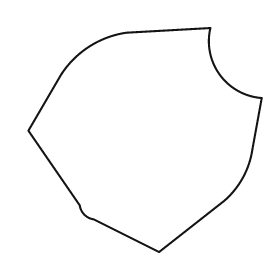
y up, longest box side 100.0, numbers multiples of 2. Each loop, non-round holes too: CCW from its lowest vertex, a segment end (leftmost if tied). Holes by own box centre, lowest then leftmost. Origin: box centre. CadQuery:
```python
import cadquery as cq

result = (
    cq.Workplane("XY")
    .moveTo(6.0, -48.0)
    .lineTo(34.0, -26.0)
    .threePointArc((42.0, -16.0), (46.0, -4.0))
    .lineTo(50.0, 18.0)
    .threePointArc((32.0, 28.0), (28.0, 48.0))
    .lineTo(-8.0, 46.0)
    .threePointArc((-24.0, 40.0), (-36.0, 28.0))
    .lineTo(-50.0, 4.0)
    .lineTo(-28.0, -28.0)
    .threePointArc((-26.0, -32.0), (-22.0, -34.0))
    .close()
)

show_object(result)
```